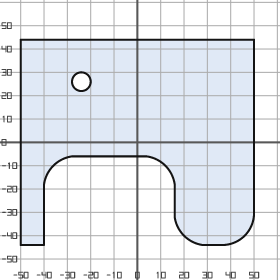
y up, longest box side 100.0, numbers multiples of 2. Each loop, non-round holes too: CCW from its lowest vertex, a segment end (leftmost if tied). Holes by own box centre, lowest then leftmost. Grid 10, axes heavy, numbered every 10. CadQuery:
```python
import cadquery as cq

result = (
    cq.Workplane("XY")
    .moveTo(-50.0, -44.0)
    .lineTo(-40.0, -44.0)
    .lineTo(-40.0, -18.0)
    .threePointArc((-36.0, -10.0), (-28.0, -6.0))
    .lineTo(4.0, -6.0)
    .threePointArc((12.0, -10.0), (16.0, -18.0))
    .lineTo(16.0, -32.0)
    .threePointArc((20.0, -40.0), (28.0, -44.0))
    .lineTo(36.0, -44.0)
    .threePointArc((46.0, -40.0), (50.0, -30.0))
    .lineTo(50.0, 44.0)
    .lineTo(-50.0, 44.0)
    .close()
    .moveTo(-24.0, 26.0)
    .circle(4.0)
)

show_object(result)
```